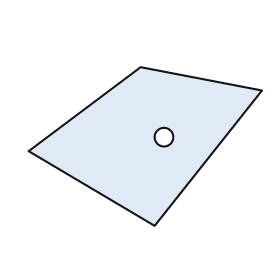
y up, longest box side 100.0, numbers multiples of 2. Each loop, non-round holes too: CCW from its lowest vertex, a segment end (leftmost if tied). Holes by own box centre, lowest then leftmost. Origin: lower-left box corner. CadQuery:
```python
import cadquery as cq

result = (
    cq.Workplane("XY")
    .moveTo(54.0, 0.0)
    .lineTo(100.0, 58.0)
    .lineTo(48.0, 68.0)
    .lineTo(0.0, 32.0)
    .close()
    .moveTo(58.0, 38.0)
    .circle(4.0)
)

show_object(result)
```